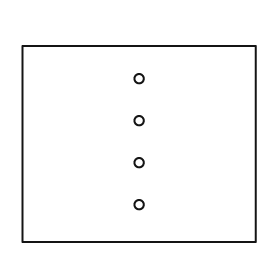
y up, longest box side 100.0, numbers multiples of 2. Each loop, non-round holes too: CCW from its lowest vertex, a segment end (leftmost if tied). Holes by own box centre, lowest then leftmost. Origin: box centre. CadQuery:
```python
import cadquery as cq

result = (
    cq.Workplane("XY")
    .moveTo(-50.0, -42.0)
    .lineTo(50.0, -42.0)
    .lineTo(50.0, 42.0)
    .lineTo(-50.0, 42.0)
    .close()
    .moveTo(0.0, -26.0)
    .circle(2.0)
    .moveTo(0.0, -8.0)
    .circle(2.0)
    .moveTo(0.0, 10.0)
    .circle(2.0)
    .moveTo(0.0, 28.0)
    .circle(2.0)
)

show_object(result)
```